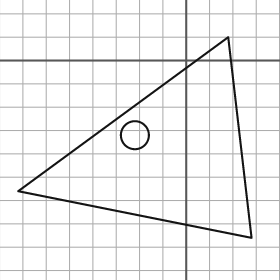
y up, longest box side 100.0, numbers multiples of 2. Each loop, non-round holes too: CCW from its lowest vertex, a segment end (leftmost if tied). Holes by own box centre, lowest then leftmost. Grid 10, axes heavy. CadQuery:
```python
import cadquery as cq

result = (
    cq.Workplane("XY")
    .moveTo(28.0, -76.0)
    .lineTo(18.0, 10.0)
    .lineTo(-72.0, -56.0)
    .close()
    .moveTo(-22.0, -32.0)
    .circle(6.0)
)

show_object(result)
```